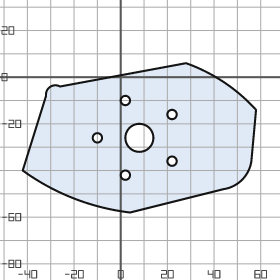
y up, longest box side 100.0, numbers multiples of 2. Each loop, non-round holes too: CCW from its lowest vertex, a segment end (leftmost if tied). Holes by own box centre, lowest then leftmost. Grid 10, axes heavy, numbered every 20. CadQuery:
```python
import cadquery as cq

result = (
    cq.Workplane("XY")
    .moveTo(4.0, -58.0)
    .lineTo(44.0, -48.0)
    .threePointArc((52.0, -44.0), (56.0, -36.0))
    .lineTo(58.0, -14.0)
    .threePointArc((44.0, -2.0), (28.0, 6.0))
    .lineTo(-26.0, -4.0)
    .threePointArc((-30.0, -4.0), (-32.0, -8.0))
    .lineTo(-42.0, -40.0)
    .threePointArc((-20.0, -52.0), (4.0, -58.0))
    .close()
    .moveTo(2.0, -42.0)
    .circle(2.0)
    .moveTo(22.0, -36.0)
    .circle(2.0)
    .moveTo(-10.0, -26.0)
    .circle(2.0)
    .moveTo(8.0, -26.0)
    .circle(6.0)
    .moveTo(22.0, -16.0)
    .circle(2.0)
    .moveTo(2.0, -10.0)
    .circle(2.0)
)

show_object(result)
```